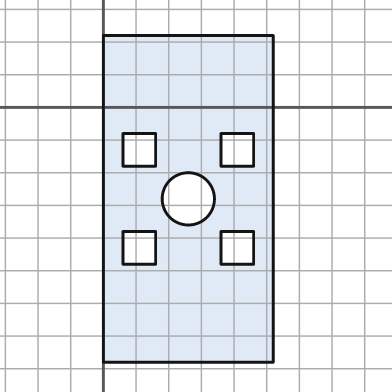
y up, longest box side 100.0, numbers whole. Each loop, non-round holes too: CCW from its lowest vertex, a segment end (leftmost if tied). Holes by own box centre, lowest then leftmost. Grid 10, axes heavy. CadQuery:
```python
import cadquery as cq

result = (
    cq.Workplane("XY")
    .moveTo(0.0, -78.0)
    .lineTo(52.0, -78.0)
    .lineTo(52.0, 22.0)
    .lineTo(0.0, 22.0)
    .close()
    .moveTo(6.0, -48.0)
    .lineTo(16.0, -48.0)
    .lineTo(16.0, -38.0)
    .lineTo(6.0, -38.0)
    .close()
    .moveTo(36.0, -48.0)
    .lineTo(46.0, -48.0)
    .lineTo(46.0, -38.0)
    .lineTo(36.0, -38.0)
    .close()
    .moveTo(26.0, -28.0)
    .circle(8.0)
    .moveTo(6.0, -18.0)
    .lineTo(16.0, -18.0)
    .lineTo(16.0, -8.0)
    .lineTo(6.0, -8.0)
    .close()
    .moveTo(36.0, -18.0)
    .lineTo(46.0, -18.0)
    .lineTo(46.0, -8.0)
    .lineTo(36.0, -8.0)
    .close()
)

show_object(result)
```